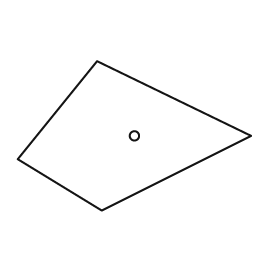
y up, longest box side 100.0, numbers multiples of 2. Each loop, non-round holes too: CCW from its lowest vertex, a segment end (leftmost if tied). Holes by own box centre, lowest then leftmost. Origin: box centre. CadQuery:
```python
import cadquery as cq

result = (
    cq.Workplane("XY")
    .moveTo(-14.0, -32.0)
    .lineTo(50.0, 0.0)
    .lineTo(-16.0, 32.0)
    .lineTo(-50.0, -10.0)
    .close()
    .moveTo(0.0, 0.0)
    .circle(2.0)
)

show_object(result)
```